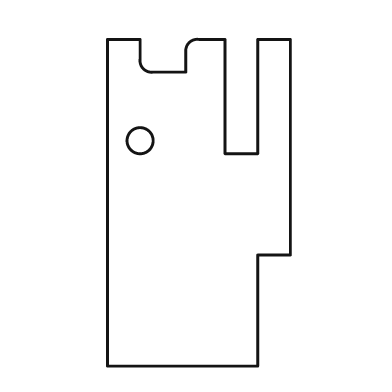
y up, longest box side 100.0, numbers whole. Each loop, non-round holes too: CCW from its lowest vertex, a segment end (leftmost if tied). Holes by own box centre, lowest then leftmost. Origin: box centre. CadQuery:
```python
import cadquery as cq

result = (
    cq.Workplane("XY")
    .moveTo(-28.0, -50.0)
    .lineTo(18.0, -50.0)
    .lineTo(18.0, -16.0)
    .lineTo(28.0, -16.0)
    .lineTo(28.0, 50.0)
    .lineTo(18.0, 50.0)
    .lineTo(18.0, 15.0)
    .lineTo(8.0, 15.0)
    .lineTo(8.0, 50.0)
    .lineTo(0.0, 50.0)
    .threePointArc((-3.0, 49.0), (-4.0, 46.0))
    .lineTo(-4.0, 40.0)
    .lineTo(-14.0, 40.0)
    .threePointArc((-17.0, 41.0), (-18.0, 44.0))
    .lineTo(-18.0, 50.0)
    .lineTo(-28.0, 50.0)
    .close()
    .moveTo(-18.0, 19.0)
    .circle(4.0)
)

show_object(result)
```